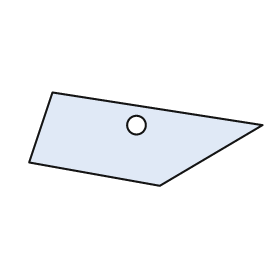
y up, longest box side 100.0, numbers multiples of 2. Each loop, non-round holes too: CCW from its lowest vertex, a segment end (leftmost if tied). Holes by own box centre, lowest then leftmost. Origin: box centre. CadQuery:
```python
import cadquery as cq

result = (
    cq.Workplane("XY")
    .moveTo(6.0, -20.0)
    .lineTo(50.0, 6.0)
    .lineTo(-40.0, 20.0)
    .lineTo(-50.0, -10.0)
    .close()
    .moveTo(-4.0, 6.0)
    .circle(4.0)
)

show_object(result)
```